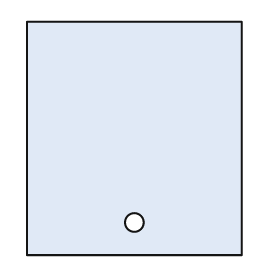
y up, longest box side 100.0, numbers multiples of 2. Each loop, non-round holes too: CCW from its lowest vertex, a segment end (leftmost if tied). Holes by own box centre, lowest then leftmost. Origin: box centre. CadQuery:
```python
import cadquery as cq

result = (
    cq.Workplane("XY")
    .moveTo(-46.0, -50.0)
    .lineTo(46.0, -50.0)
    .lineTo(46.0, 50.0)
    .lineTo(-46.0, 50.0)
    .close()
    .moveTo(0.0, -36.0)
    .circle(4.0)
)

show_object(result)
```